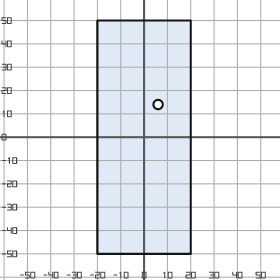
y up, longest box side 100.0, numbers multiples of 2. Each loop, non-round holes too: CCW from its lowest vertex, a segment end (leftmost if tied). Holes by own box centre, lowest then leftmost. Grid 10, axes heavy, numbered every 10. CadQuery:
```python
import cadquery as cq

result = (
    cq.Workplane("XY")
    .moveTo(-20.0, -50.0)
    .lineTo(20.0, -50.0)
    .lineTo(20.0, 50.0)
    .lineTo(-20.0, 50.0)
    .close()
    .moveTo(6.0, 14.0)
    .circle(2.0)
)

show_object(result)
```